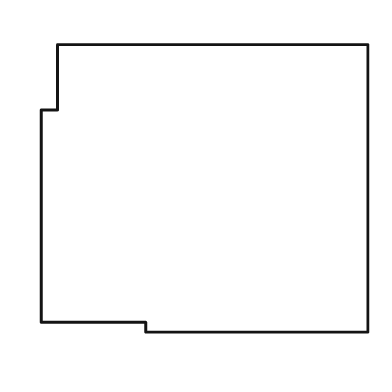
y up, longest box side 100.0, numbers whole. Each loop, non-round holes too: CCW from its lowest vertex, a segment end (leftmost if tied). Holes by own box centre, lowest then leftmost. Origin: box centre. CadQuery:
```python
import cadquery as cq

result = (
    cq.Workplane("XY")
    .moveTo(-18.0, -44.0)
    .lineTo(50.0, -44.0)
    .lineTo(50.0, 44.0)
    .lineTo(-45.0, 44.0)
    .lineTo(-45.0, 24.0)
    .lineTo(-50.0, 24.0)
    .lineTo(-50.0, -41.0)
    .lineTo(-18.0, -41.0)
    .close()
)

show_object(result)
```